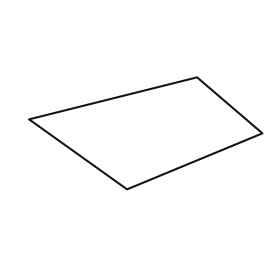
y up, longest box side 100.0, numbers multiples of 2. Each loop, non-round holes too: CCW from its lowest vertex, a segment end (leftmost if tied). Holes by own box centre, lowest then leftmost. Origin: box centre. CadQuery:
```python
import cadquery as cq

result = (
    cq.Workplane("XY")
    .moveTo(-8.0, -24.0)
    .lineTo(50.0, 0.0)
    .lineTo(22.0, 24.0)
    .lineTo(-50.0, 6.0)
    .close()
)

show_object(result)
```